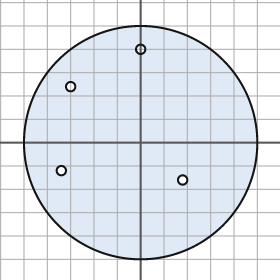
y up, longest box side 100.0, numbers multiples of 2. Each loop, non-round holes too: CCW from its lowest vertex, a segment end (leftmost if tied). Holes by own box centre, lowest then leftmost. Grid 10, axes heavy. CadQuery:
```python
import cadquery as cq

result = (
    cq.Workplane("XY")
    .moveTo(0.0, 0.0)
    .circle(50.0)
    .moveTo(18.0, -16.0)
    .circle(2.0)
    .moveTo(-34.0, -12.0)
    .circle(2.0)
    .moveTo(-30.0, 24.0)
    .circle(2.0)
    .moveTo(0.0, 40.0)
    .circle(2.0)
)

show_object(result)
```